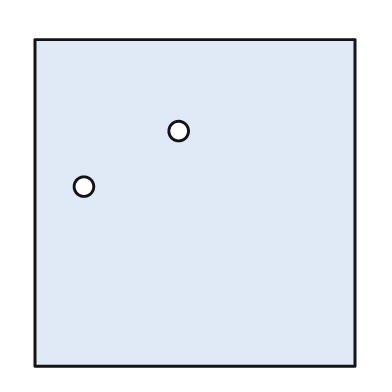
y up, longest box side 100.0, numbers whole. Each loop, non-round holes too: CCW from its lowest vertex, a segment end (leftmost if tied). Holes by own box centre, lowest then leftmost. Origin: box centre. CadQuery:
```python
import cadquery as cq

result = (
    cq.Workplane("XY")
    .moveTo(-49.0, -50.0)
    .lineTo(49.0, -50.0)
    .lineTo(49.0, 50.0)
    .lineTo(-49.0, 50.0)
    .close()
    .moveTo(-34.0, 5.0)
    .circle(3.0)
    .moveTo(-5.0, 22.0)
    .circle(3.0)
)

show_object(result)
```